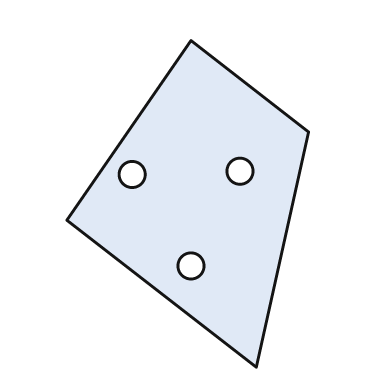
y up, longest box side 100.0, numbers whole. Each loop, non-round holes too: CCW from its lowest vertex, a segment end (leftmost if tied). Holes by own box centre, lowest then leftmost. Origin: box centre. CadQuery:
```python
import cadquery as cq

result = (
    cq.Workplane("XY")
    .moveTo(21.0, -50.0)
    .lineTo(37.0, 22.0)
    .lineTo(1.0, 50.0)
    .lineTo(-37.0, -5.0)
    .close()
    .moveTo(1.0, -19.0)
    .circle(4.0)
    .moveTo(-17.0, 9.0)
    .circle(4.0)
    .moveTo(16.0, 10.0)
    .circle(4.0)
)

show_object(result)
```